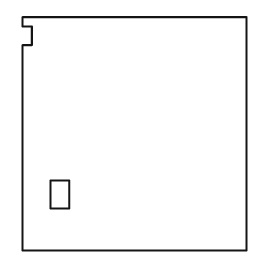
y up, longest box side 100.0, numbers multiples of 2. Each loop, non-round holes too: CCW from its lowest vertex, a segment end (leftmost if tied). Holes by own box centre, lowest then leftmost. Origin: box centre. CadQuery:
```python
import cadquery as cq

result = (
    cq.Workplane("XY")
    .moveTo(-48.0, -50.0)
    .lineTo(48.0, -50.0)
    .lineTo(48.0, 50.0)
    .lineTo(-48.0, 50.0)
    .lineTo(-48.0, 46.0)
    .lineTo(-44.0, 46.0)
    .lineTo(-44.0, 38.0)
    .lineTo(-48.0, 38.0)
    .close()
    .moveTo(-36.0, -32.0)
    .lineTo(-28.0, -32.0)
    .lineTo(-28.0, -20.0)
    .lineTo(-36.0, -20.0)
    .close()
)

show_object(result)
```